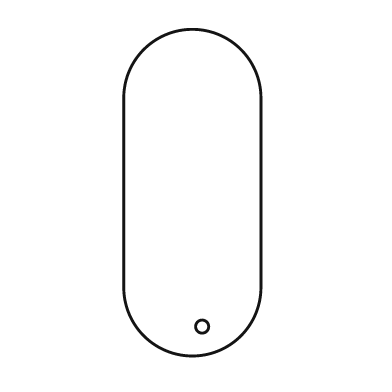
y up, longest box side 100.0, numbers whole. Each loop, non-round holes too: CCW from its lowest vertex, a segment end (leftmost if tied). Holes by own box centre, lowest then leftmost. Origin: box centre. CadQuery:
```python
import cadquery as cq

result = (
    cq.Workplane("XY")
    .moveTo(-21.0, -29.0)
    .threePointArc((0.0, -50.0), (21.0, -29.0))
    .lineTo(21.0, 29.0)
    .threePointArc((0.0, 50.0), (-21.0, 29.0))
    .close()
    .moveTo(3.0, -41.0)
    .circle(2.0)
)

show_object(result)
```